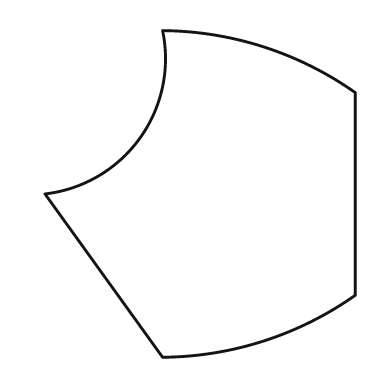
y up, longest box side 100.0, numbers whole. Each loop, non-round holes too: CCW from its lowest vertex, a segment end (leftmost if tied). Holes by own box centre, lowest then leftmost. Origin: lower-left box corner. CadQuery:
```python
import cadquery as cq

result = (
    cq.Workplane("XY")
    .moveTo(36.0, 0.0)
    .threePointArc((67.0, 5.0), (95.0, 19.0))
    .lineTo(95.0, 81.0)
    .threePointArc((67.0, 95.0), (36.0, 100.0))
    .threePointArc((29.0, 67.0), (0.0, 50.0))
    .close()
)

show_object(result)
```